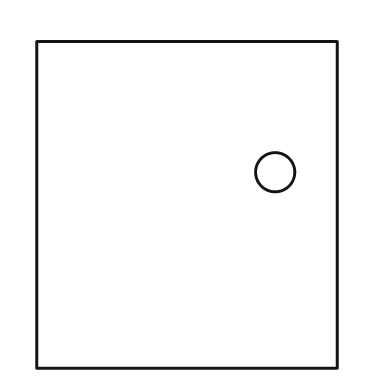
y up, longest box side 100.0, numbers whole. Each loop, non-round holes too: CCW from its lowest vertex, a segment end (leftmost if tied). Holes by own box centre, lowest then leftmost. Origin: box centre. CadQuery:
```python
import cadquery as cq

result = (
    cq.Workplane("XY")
    .moveTo(-46.0, -50.0)
    .lineTo(46.0, -50.0)
    .lineTo(46.0, 50.0)
    .lineTo(-46.0, 50.0)
    .close()
    .moveTo(27.0, 10.0)
    .circle(6.0)
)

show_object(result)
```